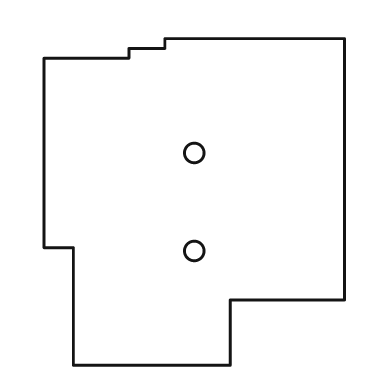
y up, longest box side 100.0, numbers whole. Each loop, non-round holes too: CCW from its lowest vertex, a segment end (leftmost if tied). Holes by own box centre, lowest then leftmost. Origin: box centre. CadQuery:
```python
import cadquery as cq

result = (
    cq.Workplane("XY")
    .moveTo(-37.0, -50.0)
    .lineTo(11.0, -50.0)
    .lineTo(11.0, -30.0)
    .lineTo(46.0, -30.0)
    .lineTo(46.0, 50.0)
    .lineTo(-9.0, 50.0)
    .lineTo(-9.0, 47.0)
    .lineTo(-20.0, 47.0)
    .lineTo(-20.0, 44.0)
    .lineTo(-46.0, 44.0)
    .lineTo(-46.0, -14.0)
    .lineTo(-37.0, -14.0)
    .close()
    .moveTo(0.0, -15.0)
    .circle(3.0)
    .moveTo(0.0, 15.0)
    .circle(3.0)
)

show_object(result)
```